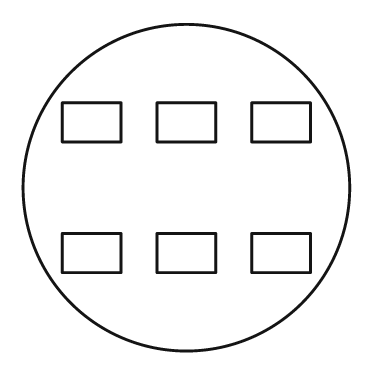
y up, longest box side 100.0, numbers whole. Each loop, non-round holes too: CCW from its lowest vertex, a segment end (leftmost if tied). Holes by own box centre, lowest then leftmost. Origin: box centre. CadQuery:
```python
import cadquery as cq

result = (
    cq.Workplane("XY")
    .moveTo(0.0, 0.0)
    .circle(50.0)
    .moveTo(-38.0, -26.0)
    .lineTo(-20.0, -26.0)
    .lineTo(-20.0, -14.0)
    .lineTo(-38.0, -14.0)
    .close()
    .moveTo(-9.0, -26.0)
    .lineTo(9.0, -26.0)
    .lineTo(9.0, -14.0)
    .lineTo(-9.0, -14.0)
    .close()
    .moveTo(20.0, -26.0)
    .lineTo(38.0, -26.0)
    .lineTo(38.0, -14.0)
    .lineTo(20.0, -14.0)
    .close()
    .moveTo(-38.0, 14.0)
    .lineTo(-20.0, 14.0)
    .lineTo(-20.0, 26.0)
    .lineTo(-38.0, 26.0)
    .close()
    .moveTo(-9.0, 14.0)
    .lineTo(9.0, 14.0)
    .lineTo(9.0, 26.0)
    .lineTo(-9.0, 26.0)
    .close()
    .moveTo(20.0, 14.0)
    .lineTo(38.0, 14.0)
    .lineTo(38.0, 26.0)
    .lineTo(20.0, 26.0)
    .close()
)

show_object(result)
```